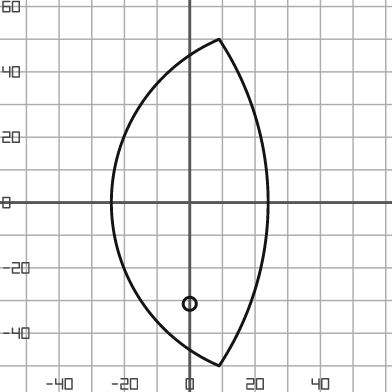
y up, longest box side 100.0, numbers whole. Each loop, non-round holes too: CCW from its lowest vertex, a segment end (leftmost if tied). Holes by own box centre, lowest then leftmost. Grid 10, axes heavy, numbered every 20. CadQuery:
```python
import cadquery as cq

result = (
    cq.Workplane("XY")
    .moveTo(9.0, -50.0)
    .threePointArc((24.0, 0.0), (9.0, 50.0))
    .threePointArc((-24.0, 0.0), (9.0, -50.0))
    .close()
    .moveTo(0.0, -31.0)
    .circle(2.0)
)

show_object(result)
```